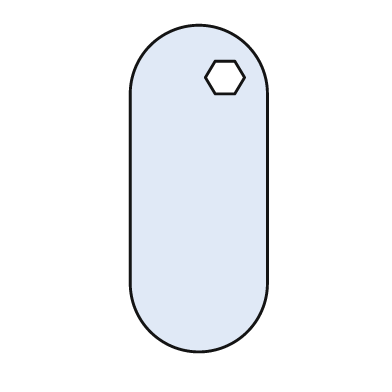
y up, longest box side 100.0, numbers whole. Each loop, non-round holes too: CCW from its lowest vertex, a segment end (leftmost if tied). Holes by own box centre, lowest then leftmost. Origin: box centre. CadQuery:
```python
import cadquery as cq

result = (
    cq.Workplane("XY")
    .moveTo(-21.0, -29.0)
    .threePointArc((0.0, -50.0), (21.0, -29.0))
    .lineTo(21.0, 29.0)
    .threePointArc((0.0, 50.0), (-21.0, 29.0))
    .close()
    .moveTo(5.0, 29.0)
    .lineTo(11.0, 29.0)
    .lineTo(14.0, 34.0)
    .lineTo(11.0, 39.0)
    .lineTo(5.0, 39.0)
    .lineTo(2.0, 34.0)
    .close()
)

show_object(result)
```